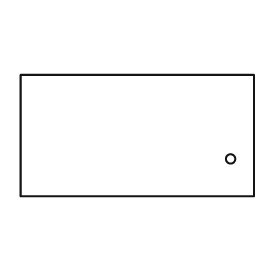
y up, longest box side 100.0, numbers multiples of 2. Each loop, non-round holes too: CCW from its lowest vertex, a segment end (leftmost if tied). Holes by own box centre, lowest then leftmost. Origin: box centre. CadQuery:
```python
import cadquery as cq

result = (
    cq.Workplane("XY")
    .moveTo(-50.0, -26.0)
    .lineTo(50.0, -26.0)
    .lineTo(50.0, 26.0)
    .lineTo(-50.0, 26.0)
    .close()
    .moveTo(40.0, -10.0)
    .circle(2.0)
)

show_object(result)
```